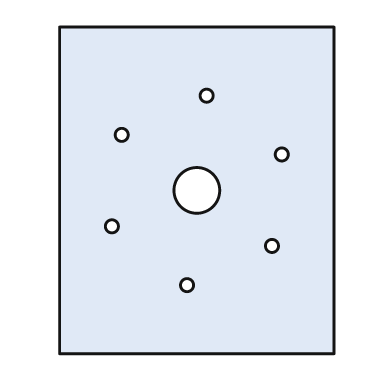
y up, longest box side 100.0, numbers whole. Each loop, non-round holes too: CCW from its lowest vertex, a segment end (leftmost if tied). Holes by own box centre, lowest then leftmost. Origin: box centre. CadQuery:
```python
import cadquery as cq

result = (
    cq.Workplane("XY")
    .moveTo(-42.0, -50.0)
    .lineTo(42.0, -50.0)
    .lineTo(42.0, 50.0)
    .lineTo(-42.0, 50.0)
    .close()
    .moveTo(-3.0, -29.0)
    .circle(2.0)
    .moveTo(23.0, -17.0)
    .circle(2.0)
    .moveTo(-26.0, -11.0)
    .circle(2.0)
    .moveTo(0.0, 0.0)
    .circle(7.0)
    .moveTo(26.0, 11.0)
    .circle(2.0)
    .moveTo(-23.0, 17.0)
    .circle(2.0)
    .moveTo(3.0, 29.0)
    .circle(2.0)
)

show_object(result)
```